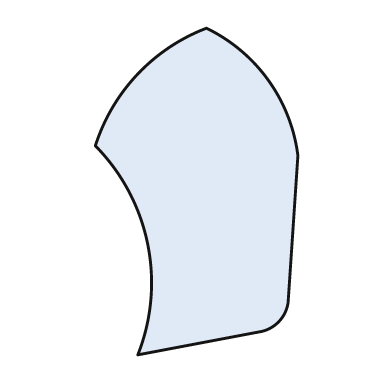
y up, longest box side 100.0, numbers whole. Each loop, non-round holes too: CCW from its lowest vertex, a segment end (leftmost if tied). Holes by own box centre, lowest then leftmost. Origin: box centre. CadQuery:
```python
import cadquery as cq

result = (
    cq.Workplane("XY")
    .moveTo(-18.0, -50.0)
    .lineTo(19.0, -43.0)
    .threePointArc((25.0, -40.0), (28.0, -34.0))
    .lineTo(31.0, 11.0)
    .threePointArc((22.0, 34.0), (3.0, 50.0))
    .threePointArc((-18.0, 36.0), (-31.0, 14.0))
    .threePointArc((-15.0, -16.0), (-18.0, -50.0))
    .close()
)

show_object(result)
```